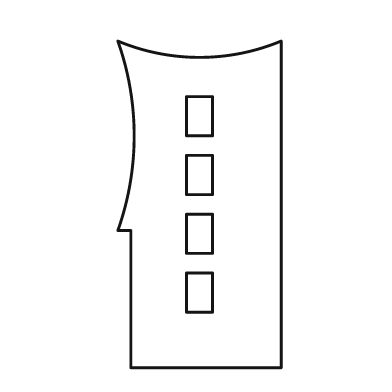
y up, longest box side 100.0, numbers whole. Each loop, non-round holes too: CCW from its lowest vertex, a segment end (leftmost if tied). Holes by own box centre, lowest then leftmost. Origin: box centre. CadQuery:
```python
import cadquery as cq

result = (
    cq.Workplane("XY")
    .moveTo(-21.0, -50.0)
    .lineTo(25.0, -50.0)
    .lineTo(25.0, 50.0)
    .threePointArc((0.0, 45.0), (-25.0, 50.0))
    .threePointArc((-20.0, 21.0), (-25.0, -8.0))
    .lineTo(-21.0, -8.0)
    .close()
    .moveTo(-4.0, -33.0)
    .lineTo(4.0, -33.0)
    .lineTo(4.0, -21.0)
    .lineTo(-4.0, -21.0)
    .close()
    .moveTo(-4.0, -15.0)
    .lineTo(4.0, -15.0)
    .lineTo(4.0, -3.0)
    .lineTo(-4.0, -3.0)
    .close()
    .moveTo(-4.0, 3.0)
    .lineTo(4.0, 3.0)
    .lineTo(4.0, 15.0)
    .lineTo(-4.0, 15.0)
    .close()
    .moveTo(-4.0, 21.0)
    .lineTo(4.0, 21.0)
    .lineTo(4.0, 33.0)
    .lineTo(-4.0, 33.0)
    .close()
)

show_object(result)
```